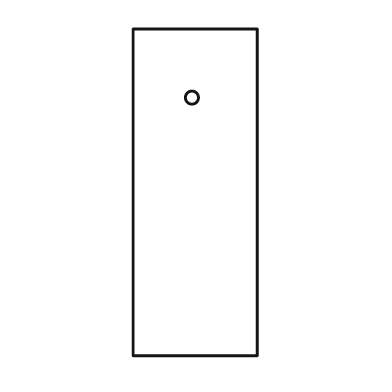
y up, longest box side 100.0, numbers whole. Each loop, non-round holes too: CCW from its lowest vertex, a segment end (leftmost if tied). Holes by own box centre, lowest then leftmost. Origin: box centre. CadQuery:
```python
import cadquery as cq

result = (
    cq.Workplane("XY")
    .moveTo(-19.0, -50.0)
    .lineTo(19.0, -50.0)
    .lineTo(19.0, 50.0)
    .lineTo(-19.0, 50.0)
    .close()
    .moveTo(-1.0, 29.0)
    .circle(2.0)
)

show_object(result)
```